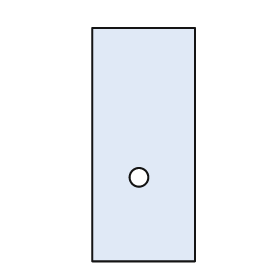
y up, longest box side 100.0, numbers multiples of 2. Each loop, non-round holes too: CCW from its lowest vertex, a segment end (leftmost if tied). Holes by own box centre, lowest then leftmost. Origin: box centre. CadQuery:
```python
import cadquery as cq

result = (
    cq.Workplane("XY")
    .moveTo(-22.0, -50.0)
    .lineTo(22.0, -50.0)
    .lineTo(22.0, 50.0)
    .lineTo(-22.0, 50.0)
    .close()
    .moveTo(-2.0, -14.0)
    .circle(4.0)
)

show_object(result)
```